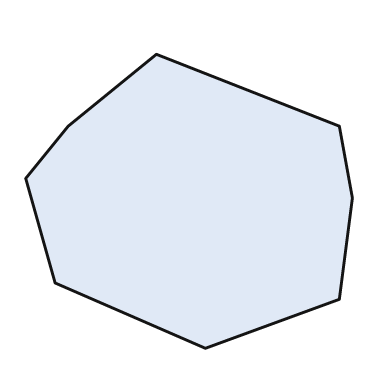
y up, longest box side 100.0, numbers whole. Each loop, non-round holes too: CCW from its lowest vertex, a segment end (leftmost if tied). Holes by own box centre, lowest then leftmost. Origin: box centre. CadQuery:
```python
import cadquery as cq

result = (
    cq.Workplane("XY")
    .moveTo(5.0, -45.0)
    .lineTo(46.0, -30.0)
    .lineTo(50.0, 1.0)
    .lineTo(46.0, 23.0)
    .lineTo(-10.0, 45.0)
    .lineTo(-37.0, 23.0)
    .lineTo(-50.0, 7.0)
    .lineTo(-41.0, -25.0)
    .close()
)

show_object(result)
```